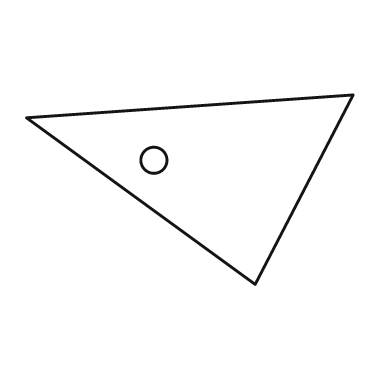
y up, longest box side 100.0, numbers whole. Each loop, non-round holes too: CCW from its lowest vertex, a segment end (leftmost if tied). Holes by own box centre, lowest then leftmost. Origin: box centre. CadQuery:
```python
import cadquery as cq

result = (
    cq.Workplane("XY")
    .moveTo(20.0, -29.0)
    .lineTo(50.0, 29.0)
    .lineTo(-50.0, 22.0)
    .close()
    .moveTo(-11.0, 9.0)
    .circle(4.0)
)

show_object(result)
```